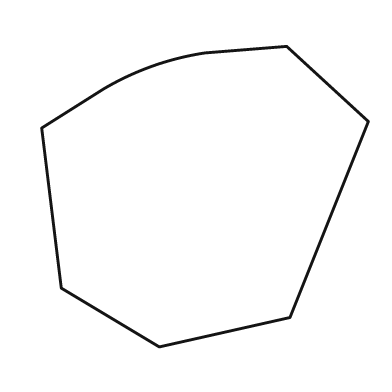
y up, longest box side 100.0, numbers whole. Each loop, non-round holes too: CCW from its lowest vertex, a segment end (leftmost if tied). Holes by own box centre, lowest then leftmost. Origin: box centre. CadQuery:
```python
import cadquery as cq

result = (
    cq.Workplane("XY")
    .moveTo(-14.0, -46.0)
    .lineTo(26.0, -37.0)
    .lineTo(50.0, 23.0)
    .lineTo(25.0, 46.0)
    .lineTo(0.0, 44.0)
    .threePointArc((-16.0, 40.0), (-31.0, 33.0))
    .lineTo(-50.0, 21.0)
    .lineTo(-44.0, -28.0)
    .close()
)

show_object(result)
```